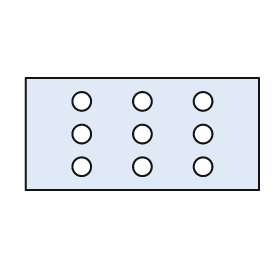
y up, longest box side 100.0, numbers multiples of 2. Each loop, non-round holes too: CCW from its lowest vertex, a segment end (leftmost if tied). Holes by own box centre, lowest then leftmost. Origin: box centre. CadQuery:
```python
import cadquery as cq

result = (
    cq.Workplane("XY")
    .moveTo(-50.0, -24.0)
    .lineTo(50.0, -24.0)
    .lineTo(50.0, 24.0)
    .lineTo(-50.0, 24.0)
    .close()
    .moveTo(-26.0, -14.0)
    .circle(4.0)
    .moveTo(0.0, -14.0)
    .circle(4.0)
    .moveTo(26.0, -14.0)
    .circle(4.0)
    .moveTo(-26.0, 0.0)
    .circle(4.0)
    .moveTo(0.0, 0.0)
    .circle(4.0)
    .moveTo(26.0, 0.0)
    .circle(4.0)
    .moveTo(-26.0, 14.0)
    .circle(4.0)
    .moveTo(0.0, 14.0)
    .circle(4.0)
    .moveTo(26.0, 14.0)
    .circle(4.0)
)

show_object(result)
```